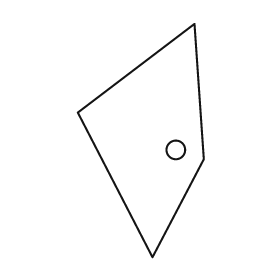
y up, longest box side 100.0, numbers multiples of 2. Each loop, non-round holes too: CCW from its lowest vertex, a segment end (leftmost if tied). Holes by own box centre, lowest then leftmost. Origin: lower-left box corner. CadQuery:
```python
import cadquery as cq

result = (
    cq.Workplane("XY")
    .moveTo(32.0, 0.0)
    .lineTo(54.0, 42.0)
    .lineTo(50.0, 100.0)
    .lineTo(0.0, 62.0)
    .close()
    .moveTo(42.0, 46.0)
    .circle(4.0)
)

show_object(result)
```